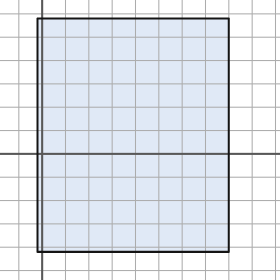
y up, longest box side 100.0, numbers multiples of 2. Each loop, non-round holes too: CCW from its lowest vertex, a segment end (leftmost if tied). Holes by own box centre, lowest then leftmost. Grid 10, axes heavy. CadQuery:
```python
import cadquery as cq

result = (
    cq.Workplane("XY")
    .moveTo(-2.0, -42.0)
    .lineTo(80.0, -42.0)
    .lineTo(80.0, 58.0)
    .lineTo(-2.0, 58.0)
    .close()
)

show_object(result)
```